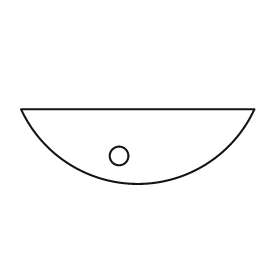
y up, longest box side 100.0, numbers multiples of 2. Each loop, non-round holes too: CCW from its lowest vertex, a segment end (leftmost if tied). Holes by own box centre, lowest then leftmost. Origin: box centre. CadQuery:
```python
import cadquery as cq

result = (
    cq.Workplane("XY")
    .moveTo(-50.0, 16.0)
    .threePointArc((0.0, -16.0), (50.0, 16.0))
    .close()
    .moveTo(-8.0, -4.0)
    .circle(4.0)
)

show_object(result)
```